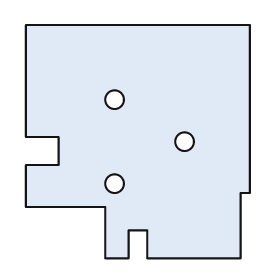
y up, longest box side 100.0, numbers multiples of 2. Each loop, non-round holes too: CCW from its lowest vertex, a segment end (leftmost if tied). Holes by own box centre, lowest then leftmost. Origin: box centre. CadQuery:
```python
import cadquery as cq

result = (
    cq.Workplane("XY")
    .moveTo(-14.0, -50.0)
    .lineTo(-4.0, -50.0)
    .lineTo(-4.0, -38.0)
    .lineTo(4.0, -38.0)
    .lineTo(4.0, -50.0)
    .lineTo(44.0, -50.0)
    .lineTo(44.0, -22.0)
    .lineTo(48.0, -22.0)
    .lineTo(48.0, 50.0)
    .lineTo(-48.0, 50.0)
    .lineTo(-48.0, 2.0)
    .lineTo(-34.0, 2.0)
    .lineTo(-34.0, -10.0)
    .lineTo(-48.0, -10.0)
    .lineTo(-48.0, -28.0)
    .lineTo(-14.0, -28.0)
    .close()
    .moveTo(-10.0, -18.0)
    .circle(4.0)
    .moveTo(20.0, 0.0)
    .circle(4.0)
    .moveTo(-10.0, 18.0)
    .circle(4.0)
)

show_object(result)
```